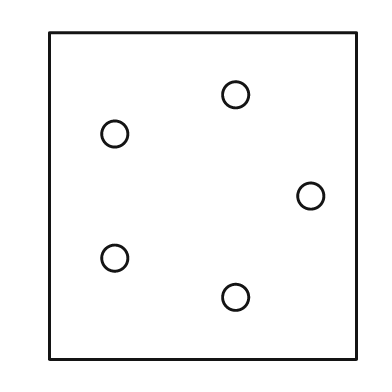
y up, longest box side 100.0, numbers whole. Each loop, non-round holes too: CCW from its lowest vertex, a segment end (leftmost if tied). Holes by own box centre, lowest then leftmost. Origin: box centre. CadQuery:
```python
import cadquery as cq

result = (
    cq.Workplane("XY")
    .moveTo(-47.0, -50.0)
    .lineTo(47.0, -50.0)
    .lineTo(47.0, 50.0)
    .lineTo(-47.0, 50.0)
    .close()
    .moveTo(10.0, -31.0)
    .circle(4.0)
    .moveTo(-27.0, -19.0)
    .circle(4.0)
    .moveTo(33.0, 0.0)
    .circle(4.0)
    .moveTo(-27.0, 19.0)
    .circle(4.0)
    .moveTo(10.0, 31.0)
    .circle(4.0)
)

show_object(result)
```